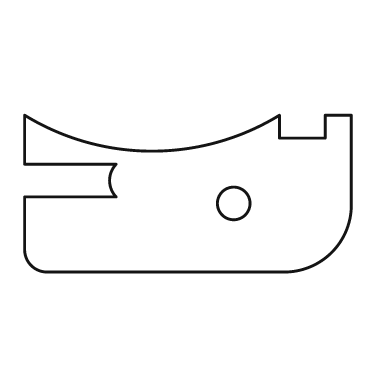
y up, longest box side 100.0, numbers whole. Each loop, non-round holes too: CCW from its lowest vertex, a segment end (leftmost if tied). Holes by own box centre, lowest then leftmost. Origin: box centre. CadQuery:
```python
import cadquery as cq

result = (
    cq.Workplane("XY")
    .moveTo(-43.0, -24.0)
    .lineTo(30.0, -24.0)
    .threePointArc((44.0, -18.0), (50.0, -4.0))
    .lineTo(50.0, 24.0)
    .lineTo(42.0, 24.0)
    .lineTo(42.0, 17.0)
    .lineTo(28.0, 17.0)
    .lineTo(28.0, 24.0)
    .threePointArc((-11.0, 13.0), (-50.0, 24.0))
    .lineTo(-50.0, 9.0)
    .lineTo(-22.0, 9.0)
    .threePointArc((-24.0, 4.0), (-22.0, -1.0))
    .lineTo(-50.0, -1.0)
    .lineTo(-50.0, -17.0)
    .threePointArc((-48.0, -22.0), (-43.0, -24.0))
    .close()
    .moveTo(14.0, -3.0)
    .circle(5.0)
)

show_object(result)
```